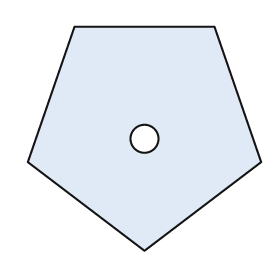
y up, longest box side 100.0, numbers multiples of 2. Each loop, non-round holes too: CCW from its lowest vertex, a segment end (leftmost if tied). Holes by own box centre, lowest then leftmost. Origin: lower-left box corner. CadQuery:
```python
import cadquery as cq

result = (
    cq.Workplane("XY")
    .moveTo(50.0, 0.0)
    .lineTo(100.0, 38.0)
    .lineTo(80.0, 96.0)
    .lineTo(20.0, 96.0)
    .lineTo(0.0, 38.0)
    .close()
    .moveTo(50.0, 48.0)
    .circle(6.0)
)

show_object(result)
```